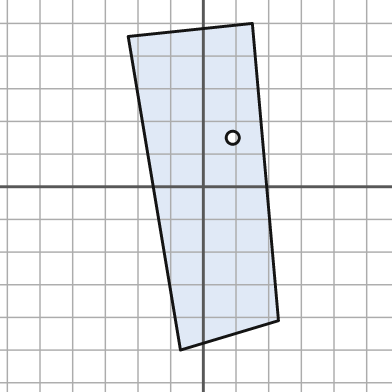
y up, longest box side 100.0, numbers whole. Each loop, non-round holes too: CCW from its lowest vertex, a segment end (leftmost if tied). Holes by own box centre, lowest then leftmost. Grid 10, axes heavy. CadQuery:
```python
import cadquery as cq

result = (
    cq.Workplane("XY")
    .moveTo(-7.0, -50.0)
    .lineTo(23.0, -41.0)
    .lineTo(15.0, 50.0)
    .lineTo(-23.0, 46.0)
    .close()
    .moveTo(9.0, 15.0)
    .circle(2.0)
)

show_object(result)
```